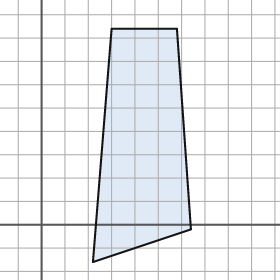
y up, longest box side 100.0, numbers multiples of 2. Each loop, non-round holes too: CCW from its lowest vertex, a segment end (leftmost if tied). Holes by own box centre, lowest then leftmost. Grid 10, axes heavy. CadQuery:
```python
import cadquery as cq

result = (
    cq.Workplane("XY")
    .moveTo(22.0, -16.0)
    .lineTo(64.0, -2.0)
    .lineTo(58.0, 84.0)
    .lineTo(30.0, 84.0)
    .close()
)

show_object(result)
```